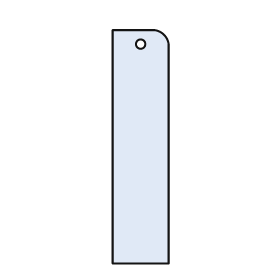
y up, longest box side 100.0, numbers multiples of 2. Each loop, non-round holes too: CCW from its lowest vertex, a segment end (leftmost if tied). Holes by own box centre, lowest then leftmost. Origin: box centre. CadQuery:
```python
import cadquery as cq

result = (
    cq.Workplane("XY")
    .moveTo(-12.0, -50.0)
    .lineTo(12.0, -50.0)
    .lineTo(12.0, 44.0)
    .threePointArc((10.0, 48.0), (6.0, 50.0))
    .lineTo(-12.0, 50.0)
    .close()
    .moveTo(0.0, 44.0)
    .circle(2.0)
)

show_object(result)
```